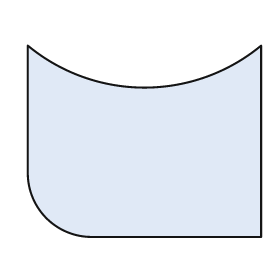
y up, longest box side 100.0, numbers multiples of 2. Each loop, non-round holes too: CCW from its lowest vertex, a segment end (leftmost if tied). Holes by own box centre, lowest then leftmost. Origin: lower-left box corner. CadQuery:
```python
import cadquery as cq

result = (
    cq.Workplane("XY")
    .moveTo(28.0, 0.0)
    .lineTo(100.0, 0.0)
    .lineTo(100.0, 82.0)
    .threePointArc((50.0, 64.0), (0.0, 82.0))
    .lineTo(0.0, 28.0)
    .threePointArc((8.0, 8.0), (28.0, 0.0))
    .close()
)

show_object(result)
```